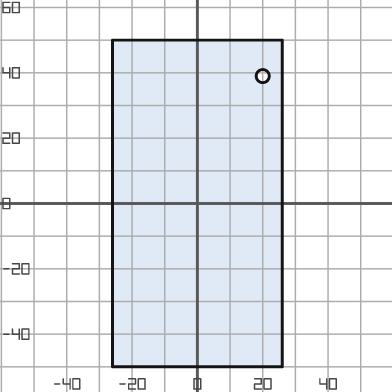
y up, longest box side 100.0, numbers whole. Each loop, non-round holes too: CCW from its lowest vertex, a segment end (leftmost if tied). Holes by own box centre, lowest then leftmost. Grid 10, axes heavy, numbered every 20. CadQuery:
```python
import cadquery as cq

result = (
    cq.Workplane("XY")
    .moveTo(-26.0, -50.0)
    .lineTo(26.0, -50.0)
    .lineTo(26.0, 50.0)
    .lineTo(-26.0, 50.0)
    .close()
    .moveTo(20.0, 39.0)
    .circle(2.0)
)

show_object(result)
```